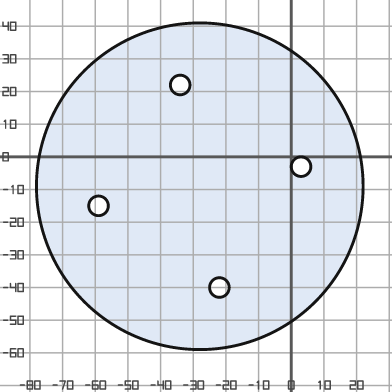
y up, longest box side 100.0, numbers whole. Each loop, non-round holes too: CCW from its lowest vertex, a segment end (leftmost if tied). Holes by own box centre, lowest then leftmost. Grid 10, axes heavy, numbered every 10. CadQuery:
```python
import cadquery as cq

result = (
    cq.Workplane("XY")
    .moveTo(-28.0, -9.0)
    .circle(50.0)
    .moveTo(-22.0, -40.0)
    .circle(3.0)
    .moveTo(-59.0, -15.0)
    .circle(3.0)
    .moveTo(3.0, -3.0)
    .circle(3.0)
    .moveTo(-34.0, 22.0)
    .circle(3.0)
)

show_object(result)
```